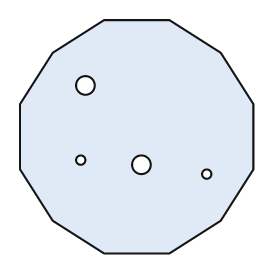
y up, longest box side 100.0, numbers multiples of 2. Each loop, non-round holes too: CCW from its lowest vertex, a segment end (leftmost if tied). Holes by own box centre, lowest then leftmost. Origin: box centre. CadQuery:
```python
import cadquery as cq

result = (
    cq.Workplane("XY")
    .moveTo(-14.0, -50.0)
    .lineTo(14.0, -50.0)
    .lineTo(36.0, -36.0)
    .lineTo(50.0, -14.0)
    .lineTo(50.0, 14.0)
    .lineTo(36.0, 36.0)
    .lineTo(14.0, 50.0)
    .lineTo(-14.0, 50.0)
    .lineTo(-36.0, 36.0)
    .lineTo(-50.0, 14.0)
    .lineTo(-50.0, -14.0)
    .lineTo(-36.0, -36.0)
    .close()
    .moveTo(30.0, -16.0)
    .circle(2.0)
    .moveTo(2.0, -12.0)
    .circle(4.0)
    .moveTo(-24.0, -10.0)
    .circle(2.0)
    .moveTo(-22.0, 22.0)
    .circle(4.0)
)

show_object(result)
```